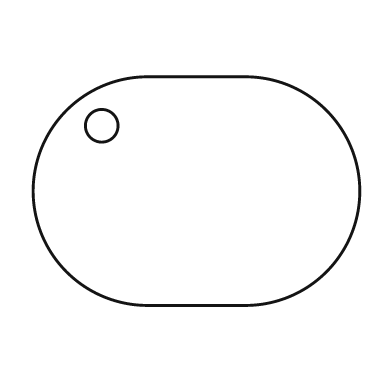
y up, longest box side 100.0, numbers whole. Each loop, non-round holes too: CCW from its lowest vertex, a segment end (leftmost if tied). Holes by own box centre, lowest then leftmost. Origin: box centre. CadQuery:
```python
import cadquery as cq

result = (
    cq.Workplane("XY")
    .moveTo(-15.0, -35.0)
    .lineTo(15.0, -35.0)
    .threePointArc((50.0, 0.0), (15.0, 35.0))
    .lineTo(-15.0, 35.0)
    .threePointArc((-50.0, 0.0), (-15.0, -35.0))
    .close()
    .moveTo(-29.0, 20.0)
    .circle(5.0)
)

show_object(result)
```